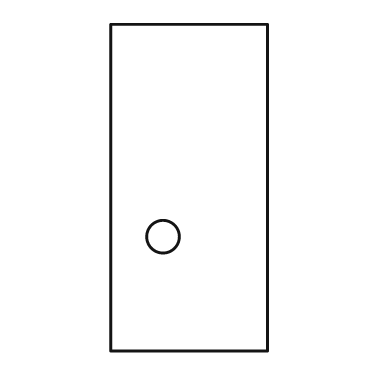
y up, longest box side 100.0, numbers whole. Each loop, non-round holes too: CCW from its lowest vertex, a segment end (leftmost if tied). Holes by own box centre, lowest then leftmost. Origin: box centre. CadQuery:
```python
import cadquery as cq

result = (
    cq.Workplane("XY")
    .moveTo(-24.0, -50.0)
    .lineTo(24.0, -50.0)
    .lineTo(24.0, 50.0)
    .lineTo(-24.0, 50.0)
    .close()
    .moveTo(-8.0, -15.0)
    .circle(5.0)
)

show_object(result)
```